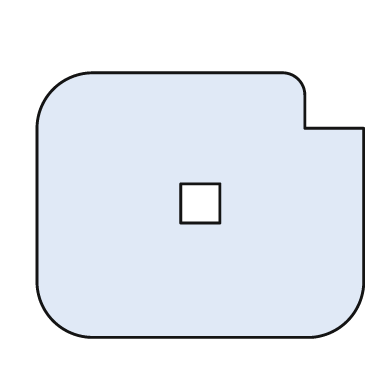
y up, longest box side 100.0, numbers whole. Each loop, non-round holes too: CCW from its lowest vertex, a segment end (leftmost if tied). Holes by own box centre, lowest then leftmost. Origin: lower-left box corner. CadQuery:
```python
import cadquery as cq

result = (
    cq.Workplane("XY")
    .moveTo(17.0, 0.0)
    .lineTo(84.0, 0.0)
    .threePointArc((95.0, 5.0), (100.0, 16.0))
    .lineTo(100.0, 64.0)
    .lineTo(82.0, 64.0)
    .lineTo(82.0, 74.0)
    .threePointArc((80.0, 79.0), (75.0, 81.0))
    .lineTo(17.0, 81.0)
    .threePointArc((5.0, 76.0), (0.0, 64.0))
    .lineTo(0.0, 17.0)
    .threePointArc((5.0, 5.0), (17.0, 0.0))
    .close()
    .moveTo(44.0, 35.0)
    .lineTo(56.0, 35.0)
    .lineTo(56.0, 47.0)
    .lineTo(44.0, 47.0)
    .close()
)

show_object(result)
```